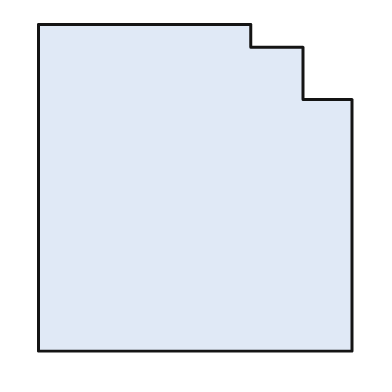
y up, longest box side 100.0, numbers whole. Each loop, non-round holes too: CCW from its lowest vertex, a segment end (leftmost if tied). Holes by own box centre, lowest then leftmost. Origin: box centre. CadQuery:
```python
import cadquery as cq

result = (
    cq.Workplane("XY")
    .moveTo(-48.0, -50.0)
    .lineTo(48.0, -50.0)
    .lineTo(48.0, 27.0)
    .lineTo(33.0, 27.0)
    .lineTo(33.0, 43.0)
    .lineTo(17.0, 43.0)
    .lineTo(17.0, 50.0)
    .lineTo(-48.0, 50.0)
    .close()
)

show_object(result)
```